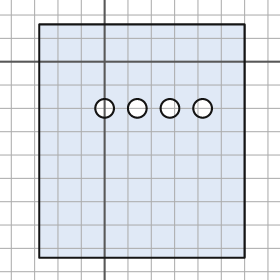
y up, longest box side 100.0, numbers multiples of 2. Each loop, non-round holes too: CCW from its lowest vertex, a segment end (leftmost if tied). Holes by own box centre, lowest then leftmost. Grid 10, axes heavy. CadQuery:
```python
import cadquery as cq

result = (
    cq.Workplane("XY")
    .moveTo(-28.0, -84.0)
    .lineTo(60.0, -84.0)
    .lineTo(60.0, 16.0)
    .lineTo(-28.0, 16.0)
    .close()
    .moveTo(0.0, -20.0)
    .circle(4.0)
    .moveTo(14.0, -20.0)
    .circle(4.0)
    .moveTo(28.0, -20.0)
    .circle(4.0)
    .moveTo(42.0, -20.0)
    .circle(4.0)
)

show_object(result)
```